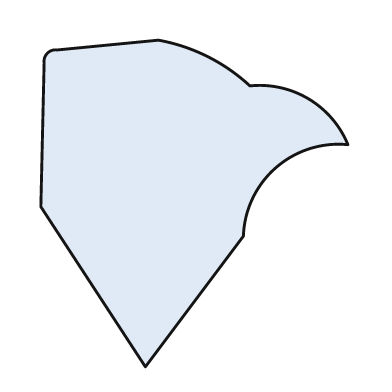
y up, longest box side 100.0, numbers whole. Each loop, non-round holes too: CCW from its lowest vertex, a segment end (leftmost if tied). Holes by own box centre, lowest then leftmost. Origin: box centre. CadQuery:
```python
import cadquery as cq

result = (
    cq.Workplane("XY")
    .moveTo(-15.0, -50.0)
    .lineTo(15.0, -10.0)
    .threePointArc((25.0, 11.0), (47.0, 18.0))
    .threePointArc((35.0, 32.0), (17.0, 36.0))
    .threePointArc((4.0, 45.0), (-11.0, 50.0))
    .lineTo(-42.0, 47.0)
    .threePointArc((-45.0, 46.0), (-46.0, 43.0))
    .lineTo(-47.0, -1.0)
    .close()
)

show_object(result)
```